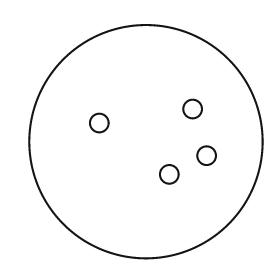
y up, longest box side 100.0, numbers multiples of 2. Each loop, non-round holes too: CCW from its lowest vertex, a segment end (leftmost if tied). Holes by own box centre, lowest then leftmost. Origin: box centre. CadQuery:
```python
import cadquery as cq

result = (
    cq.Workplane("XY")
    .moveTo(0.0, 0.0)
    .circle(50.0)
    .moveTo(10.0, -14.0)
    .circle(4.0)
    .moveTo(26.0, -6.0)
    .circle(4.0)
    .moveTo(-20.0, 8.0)
    .circle(4.0)
    .moveTo(20.0, 14.0)
    .circle(4.0)
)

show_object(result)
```